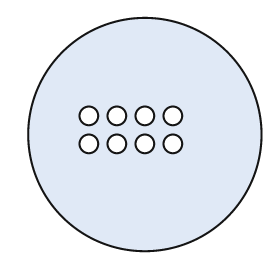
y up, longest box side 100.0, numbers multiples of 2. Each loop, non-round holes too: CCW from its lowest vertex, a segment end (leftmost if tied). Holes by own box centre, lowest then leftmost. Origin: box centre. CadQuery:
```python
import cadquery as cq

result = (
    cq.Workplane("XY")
    .moveTo(0.0, 0.0)
    .circle(50.0)
    .moveTo(-24.0, -4.0)
    .circle(4.0)
    .moveTo(-12.0, -4.0)
    .circle(4.0)
    .moveTo(0.0, -4.0)
    .circle(4.0)
    .moveTo(12.0, -4.0)
    .circle(4.0)
    .moveTo(-24.0, 8.0)
    .circle(4.0)
    .moveTo(-12.0, 8.0)
    .circle(4.0)
    .moveTo(0.0, 8.0)
    .circle(4.0)
    .moveTo(12.0, 8.0)
    .circle(4.0)
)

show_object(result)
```